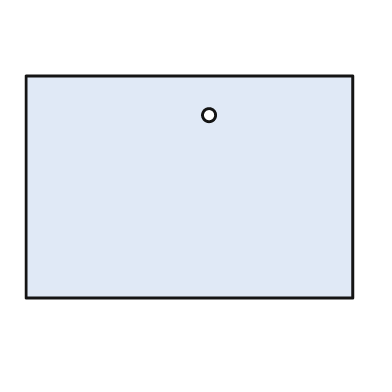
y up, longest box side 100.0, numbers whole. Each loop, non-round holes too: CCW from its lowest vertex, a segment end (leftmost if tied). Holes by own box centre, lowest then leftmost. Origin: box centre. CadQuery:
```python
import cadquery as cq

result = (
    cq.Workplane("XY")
    .moveTo(-50.0, -34.0)
    .lineTo(50.0, -34.0)
    .lineTo(50.0, 34.0)
    .lineTo(-50.0, 34.0)
    .close()
    .moveTo(6.0, 22.0)
    .circle(2.0)
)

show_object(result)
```